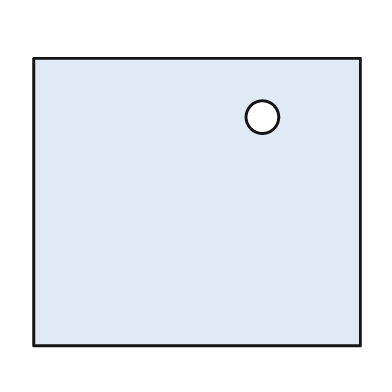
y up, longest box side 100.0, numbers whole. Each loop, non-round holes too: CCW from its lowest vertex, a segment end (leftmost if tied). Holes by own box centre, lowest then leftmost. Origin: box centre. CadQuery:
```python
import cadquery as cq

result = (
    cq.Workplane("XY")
    .moveTo(-50.0, -44.0)
    .lineTo(50.0, -44.0)
    .lineTo(50.0, 44.0)
    .lineTo(-50.0, 44.0)
    .close()
    .moveTo(20.0, 26.0)
    .circle(5.0)
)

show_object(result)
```